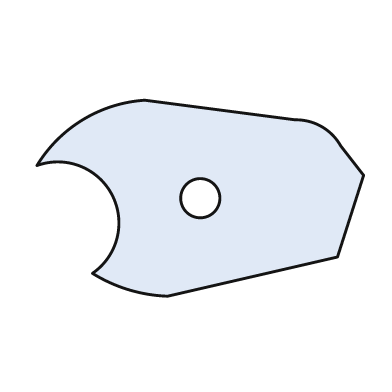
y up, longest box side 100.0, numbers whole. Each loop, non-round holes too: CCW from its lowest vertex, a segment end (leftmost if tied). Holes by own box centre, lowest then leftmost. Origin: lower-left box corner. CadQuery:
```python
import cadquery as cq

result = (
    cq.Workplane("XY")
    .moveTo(40.0, 0.0)
    .lineTo(92.0, 12.0)
    .lineTo(100.0, 37.0)
    .lineTo(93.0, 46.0)
    .threePointArc((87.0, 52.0), (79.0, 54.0))
    .lineTo(33.0, 60.0)
    .threePointArc((14.0, 54.0), (0.0, 40.0))
    .threePointArc((23.0, 31.0), (17.0, 7.0))
    .threePointArc((28.0, 2.0), (40.0, 0.0))
    .close()
    .moveTo(50.0, 30.0)
    .circle(6.0)
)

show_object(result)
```